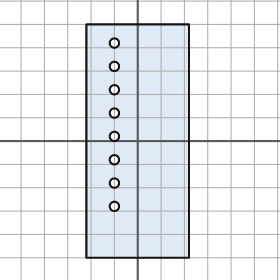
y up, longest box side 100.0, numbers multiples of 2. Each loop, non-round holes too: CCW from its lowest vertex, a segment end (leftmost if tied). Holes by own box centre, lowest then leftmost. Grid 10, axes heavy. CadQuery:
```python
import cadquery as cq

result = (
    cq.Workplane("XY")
    .moveTo(-22.0, -50.0)
    .lineTo(22.0, -50.0)
    .lineTo(22.0, 50.0)
    .lineTo(-22.0, 50.0)
    .close()
    .moveTo(-10.0, -28.0)
    .circle(2.0)
    .moveTo(-10.0, -18.0)
    .circle(2.0)
    .moveTo(-10.0, -8.0)
    .circle(2.0)
    .moveTo(-10.0, 2.0)
    .circle(2.0)
    .moveTo(-10.0, 12.0)
    .circle(2.0)
    .moveTo(-10.0, 22.0)
    .circle(2.0)
    .moveTo(-10.0, 32.0)
    .circle(2.0)
    .moveTo(-10.0, 42.0)
    .circle(2.0)
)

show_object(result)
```